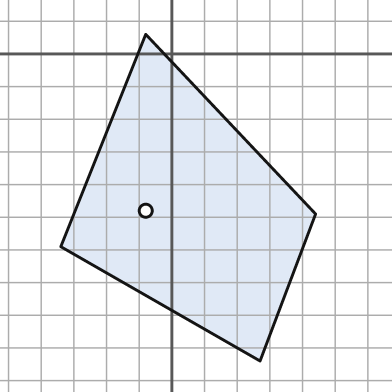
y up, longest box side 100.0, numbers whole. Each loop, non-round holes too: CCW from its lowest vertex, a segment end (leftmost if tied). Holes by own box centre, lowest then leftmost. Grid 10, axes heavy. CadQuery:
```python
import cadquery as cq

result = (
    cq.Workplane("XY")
    .moveTo(27.0, -94.0)
    .lineTo(44.0, -49.0)
    .lineTo(-8.0, 6.0)
    .lineTo(-34.0, -59.0)
    .close()
    .moveTo(-8.0, -48.0)
    .circle(2.0)
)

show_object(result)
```